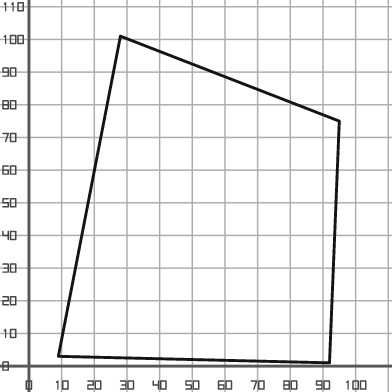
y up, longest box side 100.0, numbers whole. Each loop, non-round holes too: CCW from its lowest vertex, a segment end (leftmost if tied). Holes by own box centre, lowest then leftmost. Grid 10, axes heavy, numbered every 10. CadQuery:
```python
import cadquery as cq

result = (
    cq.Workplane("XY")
    .moveTo(92.0, 1.0)
    .lineTo(95.0, 75.0)
    .lineTo(28.0, 101.0)
    .lineTo(9.0, 3.0)
    .close()
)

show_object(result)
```